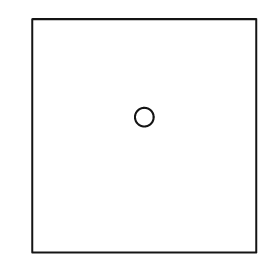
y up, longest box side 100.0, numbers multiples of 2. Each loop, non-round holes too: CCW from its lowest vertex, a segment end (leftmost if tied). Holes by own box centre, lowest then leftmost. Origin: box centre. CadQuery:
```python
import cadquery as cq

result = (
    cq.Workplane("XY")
    .moveTo(-48.0, -50.0)
    .lineTo(48.0, -50.0)
    .lineTo(48.0, 50.0)
    .lineTo(-48.0, 50.0)
    .close()
    .moveTo(0.0, 8.0)
    .circle(4.0)
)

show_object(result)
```